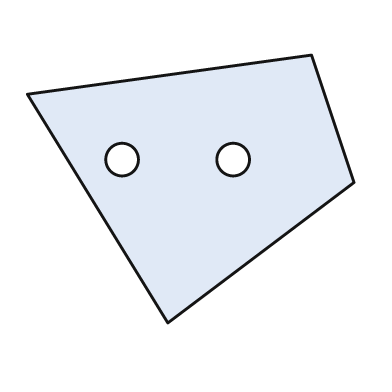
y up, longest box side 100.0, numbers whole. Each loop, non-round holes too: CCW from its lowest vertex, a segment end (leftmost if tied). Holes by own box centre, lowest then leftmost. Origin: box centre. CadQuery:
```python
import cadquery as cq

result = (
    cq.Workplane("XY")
    .moveTo(-7.0, -41.0)
    .lineTo(50.0, 2.0)
    .lineTo(37.0, 41.0)
    .lineTo(-50.0, 29.0)
    .close()
    .moveTo(-21.0, 9.0)
    .circle(5.0)
    .moveTo(13.0, 9.0)
    .circle(5.0)
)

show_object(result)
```